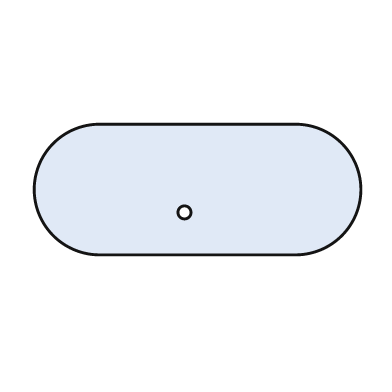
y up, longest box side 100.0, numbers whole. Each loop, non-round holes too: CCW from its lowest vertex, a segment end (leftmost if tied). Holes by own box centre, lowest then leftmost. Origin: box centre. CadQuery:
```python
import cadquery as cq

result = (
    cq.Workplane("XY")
    .moveTo(-30.0, -20.0)
    .lineTo(30.0, -20.0)
    .threePointArc((50.0, 0.0), (30.0, 20.0))
    .lineTo(-30.0, 20.0)
    .threePointArc((-50.0, 0.0), (-30.0, -20.0))
    .close()
    .moveTo(-4.0, -7.0)
    .circle(2.0)
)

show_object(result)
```